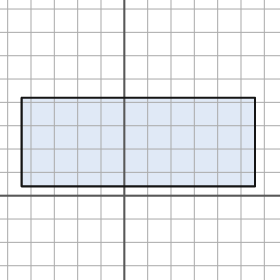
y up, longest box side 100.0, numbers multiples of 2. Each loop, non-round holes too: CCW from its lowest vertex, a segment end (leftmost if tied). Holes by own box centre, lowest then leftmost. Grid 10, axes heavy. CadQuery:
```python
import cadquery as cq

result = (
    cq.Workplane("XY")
    .moveTo(-44.0, 4.0)
    .lineTo(56.0, 4.0)
    .lineTo(56.0, 42.0)
    .lineTo(-44.0, 42.0)
    .close()
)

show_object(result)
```